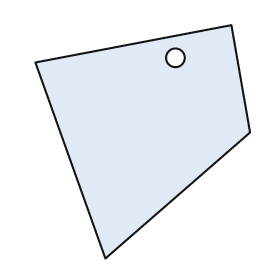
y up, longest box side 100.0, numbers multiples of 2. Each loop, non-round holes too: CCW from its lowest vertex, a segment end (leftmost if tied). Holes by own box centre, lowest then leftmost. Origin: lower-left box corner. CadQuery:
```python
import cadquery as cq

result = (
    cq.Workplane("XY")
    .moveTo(30.0, 0.0)
    .lineTo(92.0, 54.0)
    .lineTo(84.0, 100.0)
    .lineTo(0.0, 84.0)
    .close()
    .moveTo(60.0, 86.0)
    .circle(4.0)
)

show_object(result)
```